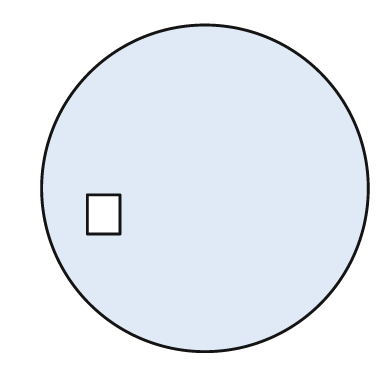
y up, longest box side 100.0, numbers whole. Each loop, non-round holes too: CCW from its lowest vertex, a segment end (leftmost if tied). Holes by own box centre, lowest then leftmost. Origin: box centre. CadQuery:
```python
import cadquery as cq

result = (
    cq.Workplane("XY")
    .moveTo(0.0, 0.0)
    .circle(50.0)
    .moveTo(-36.0, -14.0)
    .lineTo(-26.0, -14.0)
    .lineTo(-26.0, -2.0)
    .lineTo(-36.0, -2.0)
    .close()
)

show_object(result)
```